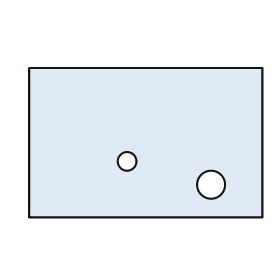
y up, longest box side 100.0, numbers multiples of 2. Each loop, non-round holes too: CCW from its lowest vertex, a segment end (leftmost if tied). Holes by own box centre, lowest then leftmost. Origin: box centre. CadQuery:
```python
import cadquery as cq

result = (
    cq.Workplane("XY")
    .moveTo(-50.0, -32.0)
    .lineTo(50.0, -32.0)
    .lineTo(50.0, 32.0)
    .lineTo(-50.0, 32.0)
    .close()
    .moveTo(28.0, -18.0)
    .circle(6.0)
    .moveTo(-8.0, -8.0)
    .circle(4.0)
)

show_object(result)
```